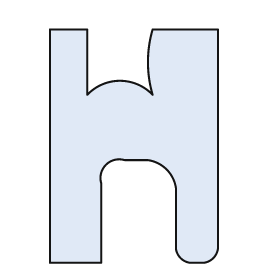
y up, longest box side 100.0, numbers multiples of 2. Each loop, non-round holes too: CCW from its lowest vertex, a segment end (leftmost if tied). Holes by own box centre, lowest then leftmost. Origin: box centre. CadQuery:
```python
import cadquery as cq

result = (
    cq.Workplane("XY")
    .moveTo(-36.0, -50.0)
    .lineTo(-14.0, -50.0)
    .lineTo(-14.0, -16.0)
    .threePointArc((-12.0, -8.0), (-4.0, -6.0))
    .lineTo(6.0, -6.0)
    .threePointArc((14.0, -10.0), (18.0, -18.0))
    .lineTo(18.0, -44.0)
    .threePointArc((20.0, -48.0), (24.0, -50.0))
    .lineTo(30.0, -50.0)
    .threePointArc((34.0, -48.0), (36.0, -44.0))
    .lineTo(36.0, 50.0)
    .lineTo(8.0, 50.0)
    .threePointArc((6.0, 36.0), (8.0, 22.0))
    .threePointArc((-6.0, 28.0), (-20.0, 22.0))
    .lineTo(-20.0, 50.0)
    .lineTo(-36.0, 50.0)
    .close()
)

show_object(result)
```